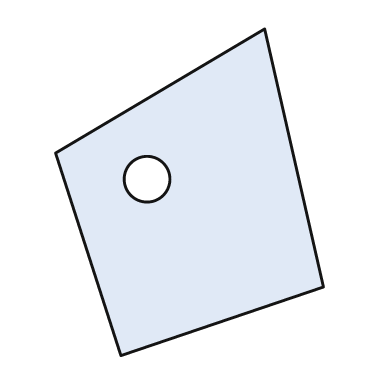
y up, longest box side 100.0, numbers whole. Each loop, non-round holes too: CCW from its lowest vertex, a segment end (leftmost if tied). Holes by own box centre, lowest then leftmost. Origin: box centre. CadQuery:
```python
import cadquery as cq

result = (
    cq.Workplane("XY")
    .moveTo(-21.0, -50.0)
    .lineTo(41.0, -29.0)
    .lineTo(23.0, 50.0)
    .lineTo(-41.0, 12.0)
    .close()
    .moveTo(-13.0, 4.0)
    .circle(7.0)
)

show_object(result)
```